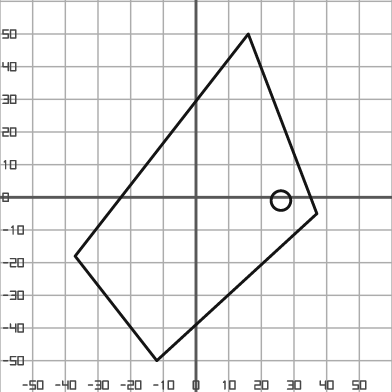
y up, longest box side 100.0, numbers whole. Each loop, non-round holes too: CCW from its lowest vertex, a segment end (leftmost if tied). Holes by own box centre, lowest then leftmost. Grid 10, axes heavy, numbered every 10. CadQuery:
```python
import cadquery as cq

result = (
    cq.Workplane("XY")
    .moveTo(-12.0, -50.0)
    .lineTo(37.0, -5.0)
    .lineTo(16.0, 50.0)
    .lineTo(-37.0, -18.0)
    .close()
    .moveTo(26.0, -1.0)
    .circle(3.0)
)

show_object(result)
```